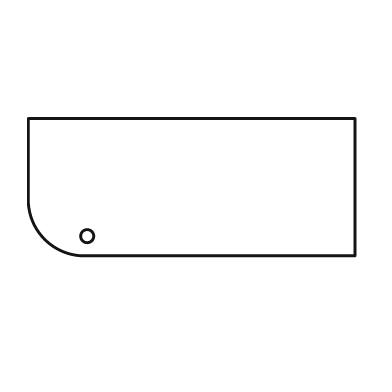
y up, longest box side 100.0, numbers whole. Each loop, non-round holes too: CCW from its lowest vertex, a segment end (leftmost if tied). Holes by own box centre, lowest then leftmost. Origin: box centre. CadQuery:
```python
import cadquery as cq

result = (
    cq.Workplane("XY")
    .moveTo(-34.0, -21.0)
    .lineTo(50.0, -21.0)
    .lineTo(50.0, 21.0)
    .lineTo(-50.0, 21.0)
    .lineTo(-50.0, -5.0)
    .threePointArc((-45.0, -16.0), (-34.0, -21.0))
    .close()
    .moveTo(-32.0, -15.0)
    .circle(2.0)
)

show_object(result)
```